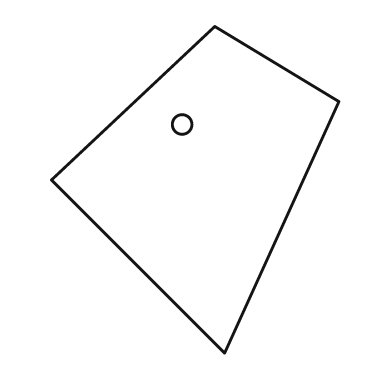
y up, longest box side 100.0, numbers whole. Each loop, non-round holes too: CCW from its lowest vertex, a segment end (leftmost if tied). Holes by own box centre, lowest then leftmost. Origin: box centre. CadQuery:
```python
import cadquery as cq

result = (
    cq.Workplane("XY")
    .moveTo(9.0, -50.0)
    .lineTo(44.0, 27.0)
    .lineTo(6.0, 50.0)
    .lineTo(-44.0, 3.0)
    .close()
    .moveTo(-4.0, 20.0)
    .circle(3.0)
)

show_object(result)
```